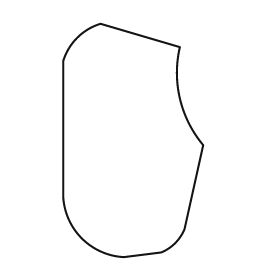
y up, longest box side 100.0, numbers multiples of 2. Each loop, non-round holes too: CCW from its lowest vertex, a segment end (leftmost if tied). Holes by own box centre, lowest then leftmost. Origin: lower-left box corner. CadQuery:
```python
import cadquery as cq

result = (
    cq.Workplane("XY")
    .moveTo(26.0, 0.0)
    .lineTo(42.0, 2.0)
    .threePointArc((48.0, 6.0), (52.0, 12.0))
    .lineTo(60.0, 48.0)
    .threePointArc((50.0, 68.0), (50.0, 90.0))
    .lineTo(16.0, 100.0)
    .threePointArc((6.0, 94.0), (0.0, 84.0))
    .lineTo(0.0, 26.0)
    .threePointArc((8.0, 8.0), (26.0, 0.0))
    .close()
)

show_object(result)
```